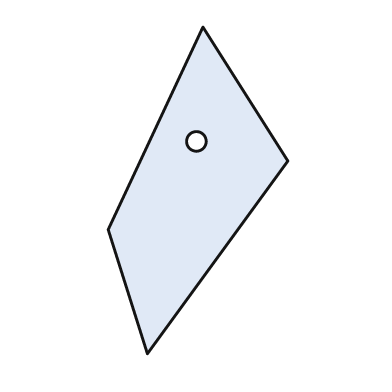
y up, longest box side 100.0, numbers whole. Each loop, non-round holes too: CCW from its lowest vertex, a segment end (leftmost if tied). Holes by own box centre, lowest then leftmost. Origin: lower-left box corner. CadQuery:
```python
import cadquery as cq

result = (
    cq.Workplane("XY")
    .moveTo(12.0, 0.0)
    .lineTo(55.0, 59.0)
    .lineTo(29.0, 100.0)
    .lineTo(0.0, 38.0)
    .close()
    .moveTo(27.0, 65.0)
    .circle(3.0)
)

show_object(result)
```